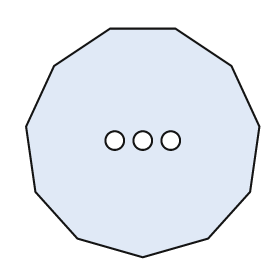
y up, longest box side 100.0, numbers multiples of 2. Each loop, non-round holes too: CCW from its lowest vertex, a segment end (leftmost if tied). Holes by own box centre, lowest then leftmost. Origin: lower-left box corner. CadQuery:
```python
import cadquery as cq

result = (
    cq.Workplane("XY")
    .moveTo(50.0, 0.0)
    .lineTo(78.0, 8.0)
    .lineTo(96.0, 28.0)
    .lineTo(100.0, 56.0)
    .lineTo(88.0, 82.0)
    .lineTo(64.0, 98.0)
    .lineTo(36.0, 98.0)
    .lineTo(12.0, 82.0)
    .lineTo(0.0, 56.0)
    .lineTo(4.0, 28.0)
    .lineTo(22.0, 8.0)
    .close()
    .moveTo(38.0, 50.0)
    .circle(4.0)
    .moveTo(50.0, 50.0)
    .circle(4.0)
    .moveTo(62.0, 50.0)
    .circle(4.0)
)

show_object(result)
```